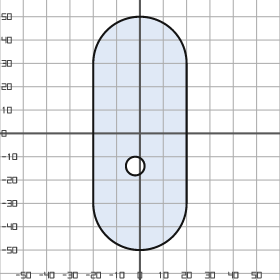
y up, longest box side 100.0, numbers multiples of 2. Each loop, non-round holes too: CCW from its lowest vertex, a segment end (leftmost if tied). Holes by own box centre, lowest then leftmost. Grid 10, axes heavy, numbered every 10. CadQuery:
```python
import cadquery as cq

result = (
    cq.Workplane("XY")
    .moveTo(-20.0, -30.0)
    .threePointArc((0.0, -50.0), (20.0, -30.0))
    .lineTo(20.0, 30.0)
    .threePointArc((0.0, 50.0), (-20.0, 30.0))
    .close()
    .moveTo(-2.0, -14.0)
    .circle(4.0)
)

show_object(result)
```